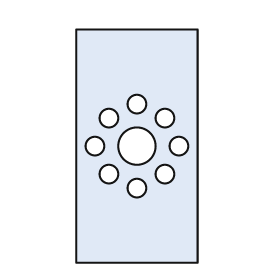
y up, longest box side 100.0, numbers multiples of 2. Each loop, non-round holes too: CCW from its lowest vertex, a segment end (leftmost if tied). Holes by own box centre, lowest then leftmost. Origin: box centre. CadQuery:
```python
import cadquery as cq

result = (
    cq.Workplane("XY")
    .moveTo(-26.0, -50.0)
    .lineTo(26.0, -50.0)
    .lineTo(26.0, 50.0)
    .lineTo(-26.0, 50.0)
    .close()
    .moveTo(0.0, -18.0)
    .circle(4.0)
    .moveTo(-12.0, -12.0)
    .circle(4.0)
    .moveTo(12.0, -12.0)
    .circle(4.0)
    .moveTo(-18.0, 0.0)
    .circle(4.0)
    .moveTo(0.0, 0.0)
    .circle(8.0)
    .moveTo(18.0, 0.0)
    .circle(4.0)
    .moveTo(-12.0, 12.0)
    .circle(4.0)
    .moveTo(12.0, 12.0)
    .circle(4.0)
    .moveTo(0.0, 18.0)
    .circle(4.0)
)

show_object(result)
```